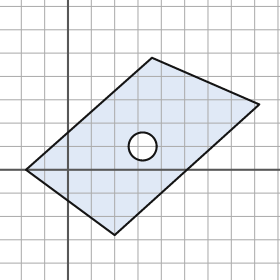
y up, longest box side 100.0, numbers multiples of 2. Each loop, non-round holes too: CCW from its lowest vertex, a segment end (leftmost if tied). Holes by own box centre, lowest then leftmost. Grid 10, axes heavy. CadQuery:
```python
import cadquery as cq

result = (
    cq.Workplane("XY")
    .moveTo(20.0, -28.0)
    .lineTo(82.0, 28.0)
    .lineTo(36.0, 48.0)
    .lineTo(-18.0, 0.0)
    .close()
    .moveTo(32.0, 10.0)
    .circle(6.0)
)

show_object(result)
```